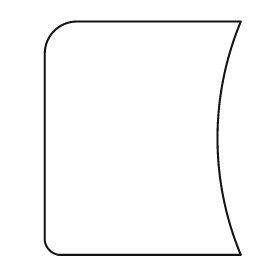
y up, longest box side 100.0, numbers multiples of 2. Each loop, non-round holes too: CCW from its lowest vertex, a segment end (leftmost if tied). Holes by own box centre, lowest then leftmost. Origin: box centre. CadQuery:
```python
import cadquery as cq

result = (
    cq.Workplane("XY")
    .moveTo(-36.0, -50.0)
    .lineTo(42.0, -50.0)
    .threePointArc((32.0, 0.0), (42.0, 50.0))
    .lineTo(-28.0, 50.0)
    .threePointArc((-38.0, 46.0), (-42.0, 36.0))
    .lineTo(-42.0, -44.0)
    .threePointArc((-40.0, -48.0), (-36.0, -50.0))
    .close()
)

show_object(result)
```